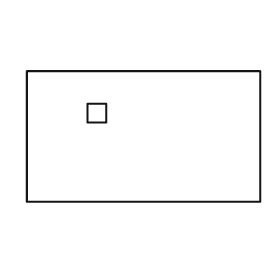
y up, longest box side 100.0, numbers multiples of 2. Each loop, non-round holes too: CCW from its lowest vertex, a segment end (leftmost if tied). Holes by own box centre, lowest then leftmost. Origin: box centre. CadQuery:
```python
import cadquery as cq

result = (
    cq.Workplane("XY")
    .moveTo(-50.0, -28.0)
    .lineTo(50.0, -28.0)
    .lineTo(50.0, 28.0)
    .lineTo(-50.0, 28.0)
    .close()
    .moveTo(-24.0, 6.0)
    .lineTo(-16.0, 6.0)
    .lineTo(-16.0, 14.0)
    .lineTo(-24.0, 14.0)
    .close()
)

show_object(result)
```